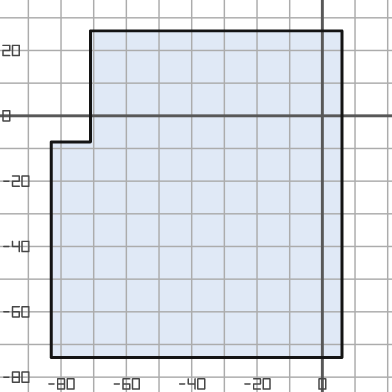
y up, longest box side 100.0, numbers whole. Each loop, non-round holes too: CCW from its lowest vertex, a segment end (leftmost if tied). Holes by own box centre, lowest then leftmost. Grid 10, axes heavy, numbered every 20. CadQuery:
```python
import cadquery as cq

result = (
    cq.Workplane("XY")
    .moveTo(-83.0, -74.0)
    .lineTo(6.0, -74.0)
    .lineTo(6.0, 26.0)
    .lineTo(-71.0, 26.0)
    .lineTo(-71.0, -8.0)
    .lineTo(-83.0, -8.0)
    .close()
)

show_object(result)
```